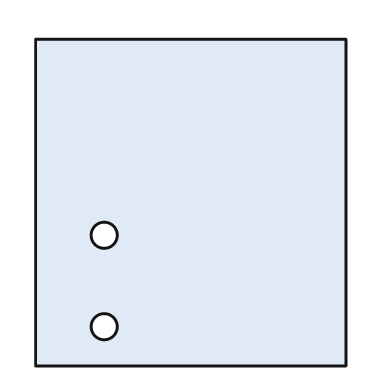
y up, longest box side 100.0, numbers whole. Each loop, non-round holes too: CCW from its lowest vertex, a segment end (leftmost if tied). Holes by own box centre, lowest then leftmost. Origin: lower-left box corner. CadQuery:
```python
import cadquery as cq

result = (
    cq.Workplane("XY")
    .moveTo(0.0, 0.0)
    .lineTo(95.0, 0.0)
    .lineTo(95.0, 100.0)
    .lineTo(0.0, 100.0)
    .close()
    .moveTo(21.0, 12.0)
    .circle(4.0)
    .moveTo(21.0, 40.0)
    .circle(4.0)
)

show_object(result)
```